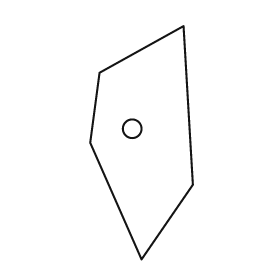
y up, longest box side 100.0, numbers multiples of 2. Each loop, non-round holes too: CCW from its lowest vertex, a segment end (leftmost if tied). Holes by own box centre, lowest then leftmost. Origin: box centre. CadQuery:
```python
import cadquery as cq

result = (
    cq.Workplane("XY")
    .moveTo(0.0, -50.0)
    .lineTo(22.0, -18.0)
    .lineTo(18.0, 50.0)
    .lineTo(-18.0, 30.0)
    .lineTo(-22.0, 0.0)
    .close()
    .moveTo(-4.0, 6.0)
    .circle(4.0)
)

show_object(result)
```